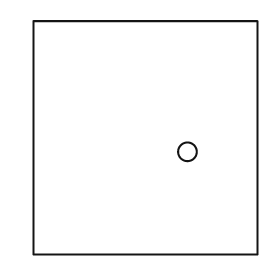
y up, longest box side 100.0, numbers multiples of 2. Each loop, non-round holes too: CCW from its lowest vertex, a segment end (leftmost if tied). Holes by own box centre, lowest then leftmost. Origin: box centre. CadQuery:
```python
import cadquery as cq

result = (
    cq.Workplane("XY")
    .moveTo(-48.0, -50.0)
    .lineTo(48.0, -50.0)
    .lineTo(48.0, 50.0)
    .lineTo(-48.0, 50.0)
    .close()
    .moveTo(18.0, -6.0)
    .circle(4.0)
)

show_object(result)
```